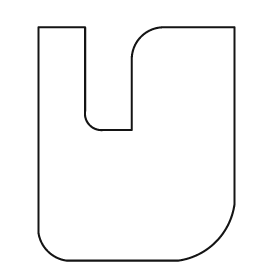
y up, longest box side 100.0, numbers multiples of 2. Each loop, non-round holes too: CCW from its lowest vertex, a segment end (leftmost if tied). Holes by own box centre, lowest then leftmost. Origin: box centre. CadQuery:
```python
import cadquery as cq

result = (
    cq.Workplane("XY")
    .moveTo(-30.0, -50.0)
    .lineTo(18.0, -50.0)
    .threePointArc((34.0, -42.0), (42.0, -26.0))
    .lineTo(42.0, 50.0)
    .lineTo(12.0, 50.0)
    .threePointArc((2.0, 46.0), (-2.0, 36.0))
    .lineTo(-2.0, 6.0)
    .lineTo(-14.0, 6.0)
    .threePointArc((-20.0, 8.0), (-22.0, 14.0))
    .lineTo(-22.0, 50.0)
    .lineTo(-42.0, 50.0)
    .lineTo(-42.0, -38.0)
    .threePointArc((-38.0, -46.0), (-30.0, -50.0))
    .close()
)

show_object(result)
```